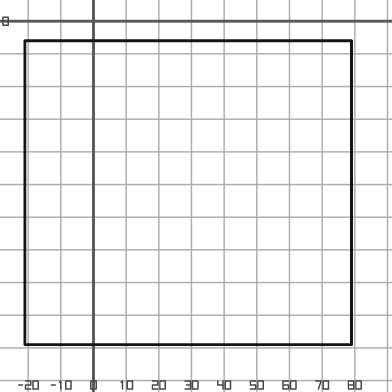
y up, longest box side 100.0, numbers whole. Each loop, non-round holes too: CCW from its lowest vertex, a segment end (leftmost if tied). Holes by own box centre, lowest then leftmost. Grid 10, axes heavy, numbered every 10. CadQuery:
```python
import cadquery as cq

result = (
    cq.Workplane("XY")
    .moveTo(-21.0, -99.0)
    .lineTo(79.0, -99.0)
    .lineTo(79.0, -6.0)
    .lineTo(-21.0, -6.0)
    .close()
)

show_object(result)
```